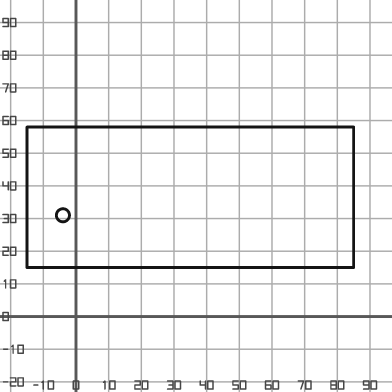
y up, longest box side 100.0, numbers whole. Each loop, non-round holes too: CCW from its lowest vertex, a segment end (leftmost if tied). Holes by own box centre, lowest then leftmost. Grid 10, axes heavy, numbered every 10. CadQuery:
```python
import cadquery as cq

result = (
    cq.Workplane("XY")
    .moveTo(-15.0, 15.0)
    .lineTo(85.0, 15.0)
    .lineTo(85.0, 58.0)
    .lineTo(-15.0, 58.0)
    .close()
    .moveTo(-4.0, 31.0)
    .circle(2.0)
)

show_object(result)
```